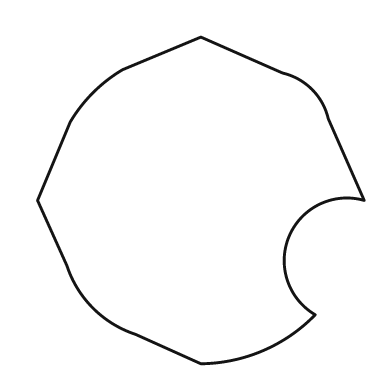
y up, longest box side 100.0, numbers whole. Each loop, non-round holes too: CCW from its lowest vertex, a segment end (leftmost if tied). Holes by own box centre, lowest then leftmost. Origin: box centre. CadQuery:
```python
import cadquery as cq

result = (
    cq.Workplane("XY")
    .moveTo(0.0, -50.0)
    .threePointArc((19.0, -46.0), (35.0, -35.0))
    .threePointArc((27.0, -11.0), (50.0, 0.0))
    .lineTo(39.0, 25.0)
    .threePointArc((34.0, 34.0), (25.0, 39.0))
    .lineTo(0.0, 50.0)
    .lineTo(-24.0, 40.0)
    .threePointArc((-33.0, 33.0), (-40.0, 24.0))
    .lineTo(-50.0, 0.0)
    .lineTo(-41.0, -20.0)
    .threePointArc((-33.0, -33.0), (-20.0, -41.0))
    .close()
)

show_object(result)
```